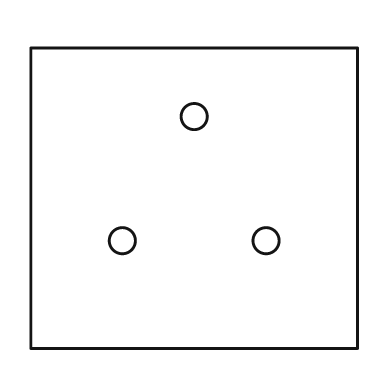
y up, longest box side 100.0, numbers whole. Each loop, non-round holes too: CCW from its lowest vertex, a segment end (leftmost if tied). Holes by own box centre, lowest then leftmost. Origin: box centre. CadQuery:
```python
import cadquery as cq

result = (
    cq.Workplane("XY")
    .moveTo(-50.0, -46.0)
    .lineTo(50.0, -46.0)
    .lineTo(50.0, 46.0)
    .lineTo(-50.0, 46.0)
    .close()
    .moveTo(-22.0, -13.0)
    .circle(4.0)
    .moveTo(22.0, -13.0)
    .circle(4.0)
    .moveTo(0.0, 25.0)
    .circle(4.0)
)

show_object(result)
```